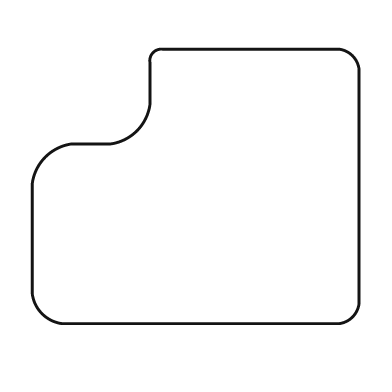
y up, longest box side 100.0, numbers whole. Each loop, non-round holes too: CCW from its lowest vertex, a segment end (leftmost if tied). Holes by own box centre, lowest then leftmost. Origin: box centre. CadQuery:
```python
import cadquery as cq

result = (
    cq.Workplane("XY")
    .moveTo(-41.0, -42.0)
    .lineTo(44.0, -42.0)
    .threePointArc((48.0, -40.0), (50.0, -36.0))
    .lineTo(50.0, 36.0)
    .threePointArc((48.0, 40.0), (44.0, 42.0))
    .lineTo(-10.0, 42.0)
    .threePointArc((-13.0, 41.0), (-14.0, 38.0))
    .lineTo(-14.0, 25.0)
    .threePointArc((-18.0, 17.0), (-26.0, 13.0))
    .lineTo(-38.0, 13.0)
    .threePointArc((-46.0, 9.0), (-50.0, 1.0))
    .lineTo(-50.0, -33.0)
    .threePointArc((-47.0, -39.0), (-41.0, -42.0))
    .close()
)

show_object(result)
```